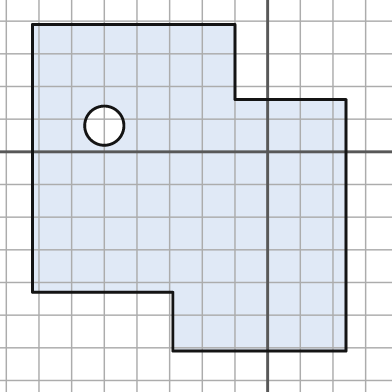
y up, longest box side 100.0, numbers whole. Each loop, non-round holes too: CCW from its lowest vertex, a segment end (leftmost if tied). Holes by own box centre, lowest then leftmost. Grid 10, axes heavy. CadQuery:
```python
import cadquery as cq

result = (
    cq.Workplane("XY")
    .moveTo(-29.0, -61.0)
    .lineTo(24.0, -61.0)
    .lineTo(24.0, 16.0)
    .lineTo(-10.0, 16.0)
    .lineTo(-10.0, 39.0)
    .lineTo(-72.0, 39.0)
    .lineTo(-72.0, -43.0)
    .lineTo(-29.0, -43.0)
    .close()
    .moveTo(-50.0, 8.0)
    .circle(6.0)
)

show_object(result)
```